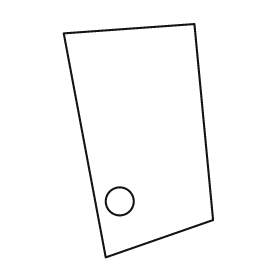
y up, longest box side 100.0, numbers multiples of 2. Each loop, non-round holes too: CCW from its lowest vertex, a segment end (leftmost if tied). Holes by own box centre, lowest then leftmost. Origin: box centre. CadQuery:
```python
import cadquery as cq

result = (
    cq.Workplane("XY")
    .moveTo(-14.0, -50.0)
    .lineTo(32.0, -34.0)
    .lineTo(24.0, 50.0)
    .lineTo(-32.0, 46.0)
    .close()
    .moveTo(-8.0, -26.0)
    .circle(6.0)
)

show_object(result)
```